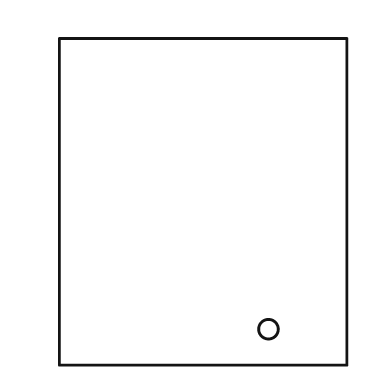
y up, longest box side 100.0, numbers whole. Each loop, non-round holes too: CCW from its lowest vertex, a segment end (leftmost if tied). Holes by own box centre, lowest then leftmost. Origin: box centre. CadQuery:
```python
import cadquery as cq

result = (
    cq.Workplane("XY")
    .moveTo(-44.0, -50.0)
    .lineTo(44.0, -50.0)
    .lineTo(44.0, 50.0)
    .lineTo(-44.0, 50.0)
    .close()
    .moveTo(20.0, -39.0)
    .circle(3.0)
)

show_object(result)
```